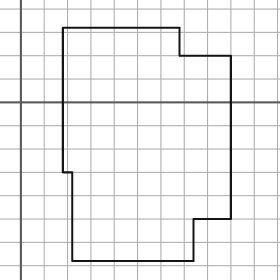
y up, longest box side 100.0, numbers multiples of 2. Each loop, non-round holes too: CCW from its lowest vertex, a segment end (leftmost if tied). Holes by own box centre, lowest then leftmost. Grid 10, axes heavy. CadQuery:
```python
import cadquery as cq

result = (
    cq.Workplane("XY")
    .moveTo(22.0, -68.0)
    .lineTo(74.0, -68.0)
    .lineTo(74.0, -50.0)
    .lineTo(90.0, -50.0)
    .lineTo(90.0, 20.0)
    .lineTo(68.0, 20.0)
    .lineTo(68.0, 32.0)
    .lineTo(18.0, 32.0)
    .lineTo(18.0, -30.0)
    .lineTo(22.0, -30.0)
    .close()
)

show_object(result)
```